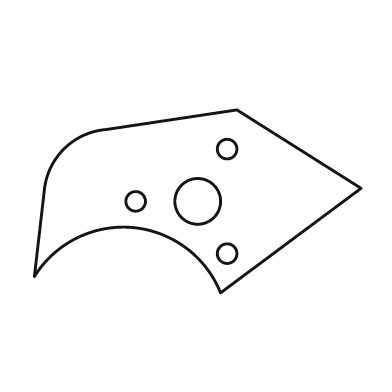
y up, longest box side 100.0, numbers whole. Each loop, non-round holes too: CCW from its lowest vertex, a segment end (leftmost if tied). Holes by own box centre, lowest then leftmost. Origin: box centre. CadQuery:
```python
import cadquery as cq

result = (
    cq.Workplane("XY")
    .moveTo(7.0, -28.0)
    .lineTo(50.0, 4.0)
    .lineTo(12.0, 28.0)
    .lineTo(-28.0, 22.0)
    .threePointArc((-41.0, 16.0), (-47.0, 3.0))
    .lineTo(-50.0, -23.0)
    .threePointArc((-20.0, -8.0), (7.0, -28.0))
    .close()
    .moveTo(9.0, -16.0)
    .circle(3.0)
    .moveTo(-19.0, 0.0)
    .circle(3.0)
    .moveTo(0.0, 0.0)
    .circle(7.0)
    .moveTo(9.0, 16.0)
    .circle(3.0)
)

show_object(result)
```